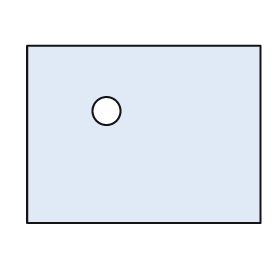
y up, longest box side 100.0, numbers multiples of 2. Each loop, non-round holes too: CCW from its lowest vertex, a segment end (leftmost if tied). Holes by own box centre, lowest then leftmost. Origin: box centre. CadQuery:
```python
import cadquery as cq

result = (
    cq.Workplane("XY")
    .moveTo(-50.0, -38.0)
    .lineTo(50.0, -38.0)
    .lineTo(50.0, 38.0)
    .lineTo(-50.0, 38.0)
    .close()
    .moveTo(-16.0, 10.0)
    .circle(6.0)
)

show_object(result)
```